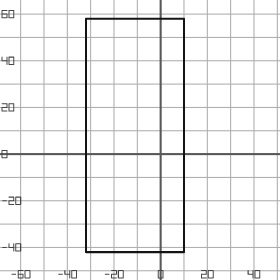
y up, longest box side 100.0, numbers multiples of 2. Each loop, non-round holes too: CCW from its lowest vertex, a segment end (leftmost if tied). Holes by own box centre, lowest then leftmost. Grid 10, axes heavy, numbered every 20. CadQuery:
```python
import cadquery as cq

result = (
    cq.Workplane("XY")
    .moveTo(-32.0, -42.0)
    .lineTo(10.0, -42.0)
    .lineTo(10.0, 58.0)
    .lineTo(-32.0, 58.0)
    .close()
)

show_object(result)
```